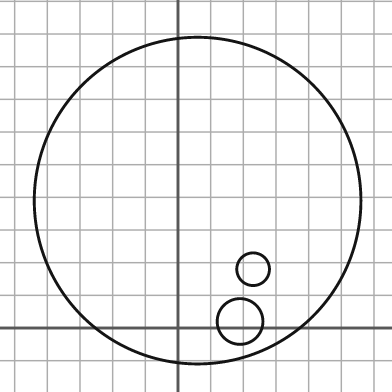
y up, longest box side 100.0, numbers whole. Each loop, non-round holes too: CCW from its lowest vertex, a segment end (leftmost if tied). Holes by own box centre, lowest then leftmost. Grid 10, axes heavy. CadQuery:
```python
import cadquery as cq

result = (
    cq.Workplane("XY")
    .moveTo(6.0, 39.0)
    .circle(50.0)
    .moveTo(19.0, 2.0)
    .circle(7.0)
    .moveTo(23.0, 18.0)
    .circle(5.0)
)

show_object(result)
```